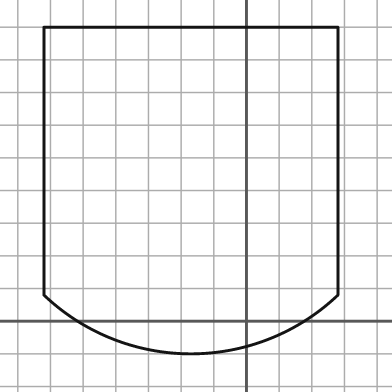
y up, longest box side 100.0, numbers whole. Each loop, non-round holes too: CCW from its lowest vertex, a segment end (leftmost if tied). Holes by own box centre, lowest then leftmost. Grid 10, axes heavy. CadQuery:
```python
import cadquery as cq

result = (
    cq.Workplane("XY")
    .moveTo(-62.0, 8.0)
    .threePointArc((-17.0, -10.0), (28.0, 8.0))
    .lineTo(28.0, 90.0)
    .lineTo(-62.0, 90.0)
    .close()
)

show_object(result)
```